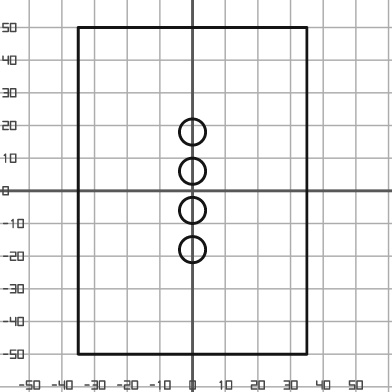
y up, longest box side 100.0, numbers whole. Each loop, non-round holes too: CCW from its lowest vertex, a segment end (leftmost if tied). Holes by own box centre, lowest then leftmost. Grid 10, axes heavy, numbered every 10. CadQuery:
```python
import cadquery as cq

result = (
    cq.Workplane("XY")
    .moveTo(-35.0, -50.0)
    .lineTo(35.0, -50.0)
    .lineTo(35.0, 50.0)
    .lineTo(-35.0, 50.0)
    .close()
    .moveTo(0.0, -18.0)
    .circle(4.0)
    .moveTo(0.0, -6.0)
    .circle(4.0)
    .moveTo(0.0, 6.0)
    .circle(4.0)
    .moveTo(0.0, 18.0)
    .circle(4.0)
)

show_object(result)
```